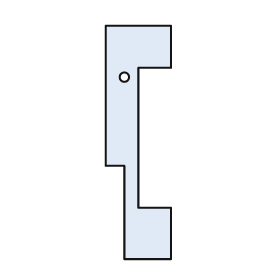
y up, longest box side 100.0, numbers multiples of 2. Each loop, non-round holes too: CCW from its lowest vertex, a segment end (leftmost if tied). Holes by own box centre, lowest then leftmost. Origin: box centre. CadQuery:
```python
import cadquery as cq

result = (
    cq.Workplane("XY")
    .moveTo(-6.0, -50.0)
    .lineTo(14.0, -50.0)
    .lineTo(14.0, -28.0)
    .lineTo(0.0, -28.0)
    .lineTo(0.0, 32.0)
    .lineTo(14.0, 32.0)
    .lineTo(14.0, 50.0)
    .lineTo(-14.0, 50.0)
    .lineTo(-14.0, -10.0)
    .lineTo(-6.0, -10.0)
    .close()
    .moveTo(-6.0, 28.0)
    .circle(2.0)
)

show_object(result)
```